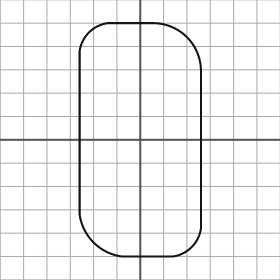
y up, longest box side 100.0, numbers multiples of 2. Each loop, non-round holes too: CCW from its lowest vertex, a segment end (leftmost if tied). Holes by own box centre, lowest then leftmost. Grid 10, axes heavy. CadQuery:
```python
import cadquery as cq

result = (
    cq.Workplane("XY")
    .moveTo(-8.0, -50.0)
    .lineTo(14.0, -50.0)
    .threePointArc((22.0, -46.0), (26.0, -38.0))
    .lineTo(26.0, 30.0)
    .threePointArc((20.0, 44.0), (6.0, 50.0))
    .lineTo(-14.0, 50.0)
    .threePointArc((-22.0, 46.0), (-26.0, 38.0))
    .lineTo(-26.0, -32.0)
    .threePointArc((-20.0, -44.0), (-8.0, -50.0))
    .close()
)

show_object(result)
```